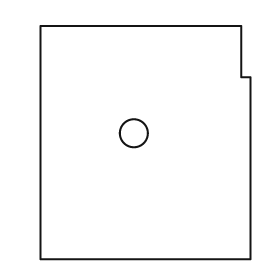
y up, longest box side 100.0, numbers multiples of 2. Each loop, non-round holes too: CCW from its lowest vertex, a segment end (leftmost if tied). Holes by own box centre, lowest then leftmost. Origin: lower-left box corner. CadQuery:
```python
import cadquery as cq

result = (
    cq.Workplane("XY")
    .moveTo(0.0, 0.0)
    .lineTo(90.0, 0.0)
    .lineTo(90.0, 78.0)
    .lineTo(86.0, 78.0)
    .lineTo(86.0, 100.0)
    .lineTo(0.0, 100.0)
    .close()
    .moveTo(40.0, 54.0)
    .circle(6.0)
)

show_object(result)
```